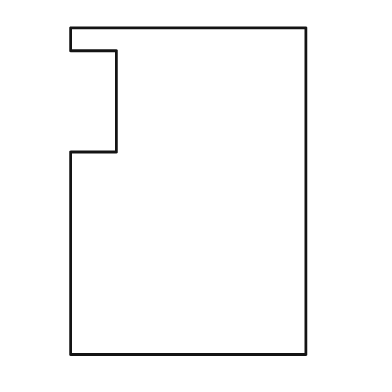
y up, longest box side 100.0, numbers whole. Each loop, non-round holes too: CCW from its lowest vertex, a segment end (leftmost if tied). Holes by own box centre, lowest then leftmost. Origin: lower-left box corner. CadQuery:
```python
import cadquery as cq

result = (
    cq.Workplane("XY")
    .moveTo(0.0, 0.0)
    .lineTo(72.0, 0.0)
    .lineTo(72.0, 100.0)
    .lineTo(0.0, 100.0)
    .lineTo(0.0, 93.0)
    .lineTo(14.0, 93.0)
    .lineTo(14.0, 62.0)
    .lineTo(0.0, 62.0)
    .close()
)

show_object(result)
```